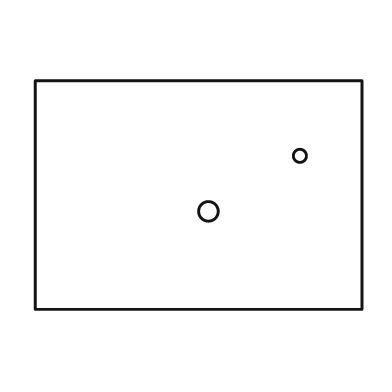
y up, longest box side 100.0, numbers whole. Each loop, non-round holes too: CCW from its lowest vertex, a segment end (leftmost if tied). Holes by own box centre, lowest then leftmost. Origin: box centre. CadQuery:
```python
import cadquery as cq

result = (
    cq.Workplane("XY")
    .moveTo(-50.0, -35.0)
    .lineTo(50.0, -35.0)
    .lineTo(50.0, 35.0)
    .lineTo(-50.0, 35.0)
    .close()
    .moveTo(3.0, -5.0)
    .circle(3.0)
    .moveTo(31.0, 12.0)
    .circle(2.0)
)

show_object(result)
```